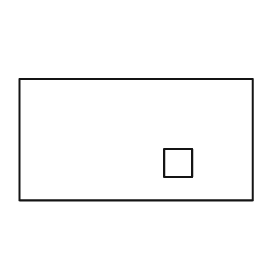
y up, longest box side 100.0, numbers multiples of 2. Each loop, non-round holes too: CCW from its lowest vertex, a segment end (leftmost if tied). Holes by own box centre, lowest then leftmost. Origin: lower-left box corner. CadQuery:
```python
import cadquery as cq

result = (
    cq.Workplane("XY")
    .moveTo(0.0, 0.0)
    .lineTo(100.0, 0.0)
    .lineTo(100.0, 52.0)
    .lineTo(0.0, 52.0)
    .close()
    .moveTo(62.0, 10.0)
    .lineTo(74.0, 10.0)
    .lineTo(74.0, 22.0)
    .lineTo(62.0, 22.0)
    .close()
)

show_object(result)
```